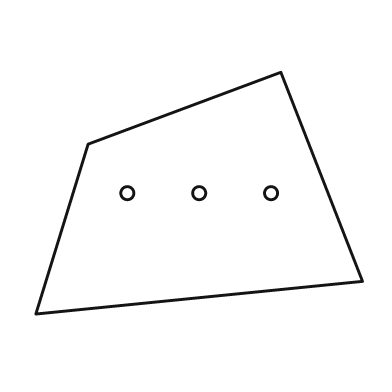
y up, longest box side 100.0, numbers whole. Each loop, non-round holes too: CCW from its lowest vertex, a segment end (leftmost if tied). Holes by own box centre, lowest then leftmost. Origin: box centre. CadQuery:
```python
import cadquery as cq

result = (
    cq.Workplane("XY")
    .moveTo(-50.0, -37.0)
    .lineTo(50.0, -27.0)
    .lineTo(25.0, 37.0)
    .lineTo(-34.0, 15.0)
    .close()
    .moveTo(-22.0, 0.0)
    .circle(2.0)
    .moveTo(0.0, 0.0)
    .circle(2.0)
    .moveTo(22.0, 0.0)
    .circle(2.0)
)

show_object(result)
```